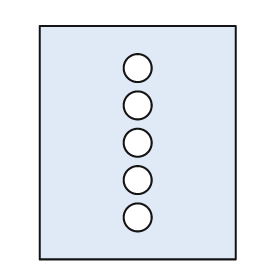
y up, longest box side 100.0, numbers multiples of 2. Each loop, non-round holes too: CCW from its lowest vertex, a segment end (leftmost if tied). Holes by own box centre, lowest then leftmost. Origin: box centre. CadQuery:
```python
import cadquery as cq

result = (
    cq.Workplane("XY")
    .moveTo(-42.0, -50.0)
    .lineTo(42.0, -50.0)
    .lineTo(42.0, 50.0)
    .lineTo(-42.0, 50.0)
    .close()
    .moveTo(0.0, -32.0)
    .circle(6.0)
    .moveTo(0.0, -16.0)
    .circle(6.0)
    .moveTo(0.0, 0.0)
    .circle(6.0)
    .moveTo(0.0, 16.0)
    .circle(6.0)
    .moveTo(0.0, 32.0)
    .circle(6.0)
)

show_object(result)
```